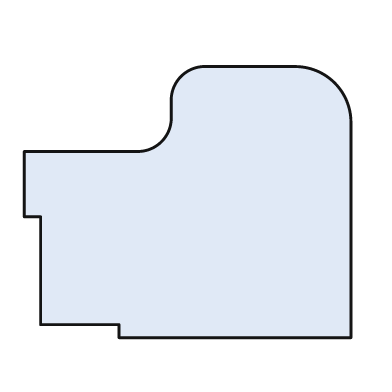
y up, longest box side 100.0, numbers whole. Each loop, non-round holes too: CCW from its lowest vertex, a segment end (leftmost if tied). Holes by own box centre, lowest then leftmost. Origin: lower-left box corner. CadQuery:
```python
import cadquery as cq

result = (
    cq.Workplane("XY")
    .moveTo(29.0, 0.0)
    .lineTo(100.0, 0.0)
    .lineTo(100.0, 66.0)
    .threePointArc((95.0, 78.0), (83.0, 83.0))
    .lineTo(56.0, 83.0)
    .threePointArc((48.0, 80.0), (45.0, 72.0))
    .lineTo(45.0, 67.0)
    .threePointArc((42.0, 60.0), (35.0, 57.0))
    .lineTo(0.0, 57.0)
    .lineTo(0.0, 37.0)
    .lineTo(5.0, 37.0)
    .lineTo(5.0, 4.0)
    .lineTo(29.0, 4.0)
    .close()
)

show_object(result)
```